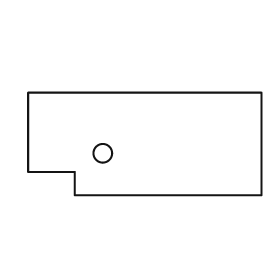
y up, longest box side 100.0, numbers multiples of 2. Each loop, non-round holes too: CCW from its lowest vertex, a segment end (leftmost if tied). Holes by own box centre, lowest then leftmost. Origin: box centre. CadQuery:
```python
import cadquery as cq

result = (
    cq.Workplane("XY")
    .moveTo(-30.0, -22.0)
    .lineTo(50.0, -22.0)
    .lineTo(50.0, 22.0)
    .lineTo(-50.0, 22.0)
    .lineTo(-50.0, -12.0)
    .lineTo(-30.0, -12.0)
    .close()
    .moveTo(-18.0, -4.0)
    .circle(4.0)
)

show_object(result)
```